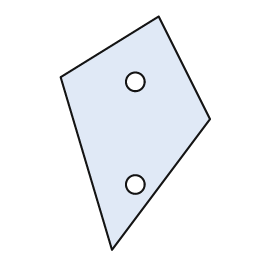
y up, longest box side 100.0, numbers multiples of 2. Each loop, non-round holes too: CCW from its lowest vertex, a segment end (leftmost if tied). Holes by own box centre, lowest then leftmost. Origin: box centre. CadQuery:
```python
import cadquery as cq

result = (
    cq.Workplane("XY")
    .moveTo(-10.0, -50.0)
    .lineTo(32.0, 6.0)
    .lineTo(10.0, 50.0)
    .lineTo(-32.0, 24.0)
    .close()
    .moveTo(0.0, -22.0)
    .circle(4.0)
    .moveTo(0.0, 22.0)
    .circle(4.0)
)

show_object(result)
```